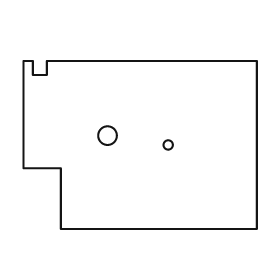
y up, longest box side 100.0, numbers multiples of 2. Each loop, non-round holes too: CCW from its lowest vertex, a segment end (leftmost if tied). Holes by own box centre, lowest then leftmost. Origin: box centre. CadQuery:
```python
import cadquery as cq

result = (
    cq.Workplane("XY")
    .moveTo(-34.0, -36.0)
    .lineTo(50.0, -36.0)
    .lineTo(50.0, 36.0)
    .lineTo(-40.0, 36.0)
    .lineTo(-40.0, 30.0)
    .lineTo(-46.0, 30.0)
    .lineTo(-46.0, 36.0)
    .lineTo(-50.0, 36.0)
    .lineTo(-50.0, -10.0)
    .lineTo(-34.0, -10.0)
    .close()
    .moveTo(12.0, 0.0)
    .circle(2.0)
    .moveTo(-14.0, 4.0)
    .circle(4.0)
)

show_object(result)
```